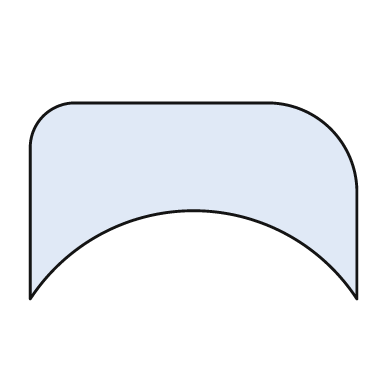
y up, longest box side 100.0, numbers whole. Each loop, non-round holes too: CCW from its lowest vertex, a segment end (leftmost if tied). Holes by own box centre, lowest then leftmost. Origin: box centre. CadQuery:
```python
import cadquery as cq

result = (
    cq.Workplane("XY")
    .moveTo(-50.0, -30.0)
    .threePointArc((0.0, -3.0), (50.0, -30.0))
    .lineTo(50.0, 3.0)
    .threePointArc((42.0, 22.0), (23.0, 30.0))
    .lineTo(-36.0, 30.0)
    .threePointArc((-46.0, 26.0), (-50.0, 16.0))
    .close()
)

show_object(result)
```